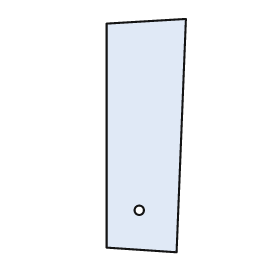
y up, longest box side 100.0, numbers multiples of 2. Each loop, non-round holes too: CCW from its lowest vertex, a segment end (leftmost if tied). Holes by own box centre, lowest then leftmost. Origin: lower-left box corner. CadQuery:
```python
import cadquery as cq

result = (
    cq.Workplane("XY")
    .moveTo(30.0, 0.0)
    .lineTo(34.0, 100.0)
    .lineTo(0.0, 98.0)
    .lineTo(0.0, 2.0)
    .close()
    .moveTo(14.0, 18.0)
    .circle(2.0)
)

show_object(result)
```